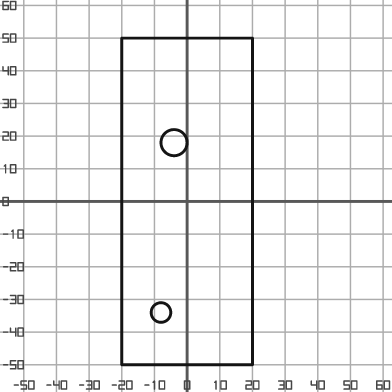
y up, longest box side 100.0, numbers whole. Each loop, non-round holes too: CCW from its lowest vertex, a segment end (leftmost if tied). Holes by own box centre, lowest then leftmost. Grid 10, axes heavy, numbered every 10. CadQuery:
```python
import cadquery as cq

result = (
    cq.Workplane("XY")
    .moveTo(-20.0, -50.0)
    .lineTo(20.0, -50.0)
    .lineTo(20.0, 50.0)
    .lineTo(-20.0, 50.0)
    .close()
    .moveTo(-8.0, -34.0)
    .circle(3.0)
    .moveTo(-4.0, 18.0)
    .circle(4.0)
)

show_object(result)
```